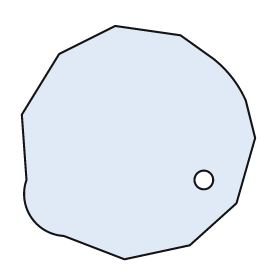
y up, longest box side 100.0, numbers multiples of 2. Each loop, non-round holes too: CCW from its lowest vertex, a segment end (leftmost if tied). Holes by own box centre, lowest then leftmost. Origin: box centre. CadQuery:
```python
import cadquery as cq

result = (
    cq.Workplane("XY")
    .moveTo(-6.0, -50.0)
    .lineTo(22.0, -44.0)
    .lineTo(42.0, -26.0)
    .lineTo(50.0, 2.0)
    .lineTo(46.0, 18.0)
    .threePointArc((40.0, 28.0), (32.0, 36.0))
    .lineTo(18.0, 46.0)
    .lineTo(-10.0, 50.0)
    .lineTo(-34.0, 38.0)
    .lineTo(-50.0, 12.0)
    .lineTo(-48.0, -16.0)
    .threePointArc((-46.0, -32.0), (-32.0, -40.0))
    .close()
    .moveTo(28.0, -16.0)
    .circle(4.0)
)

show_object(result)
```